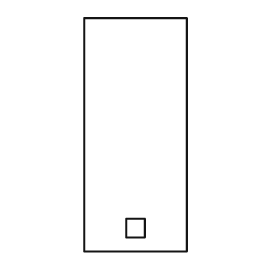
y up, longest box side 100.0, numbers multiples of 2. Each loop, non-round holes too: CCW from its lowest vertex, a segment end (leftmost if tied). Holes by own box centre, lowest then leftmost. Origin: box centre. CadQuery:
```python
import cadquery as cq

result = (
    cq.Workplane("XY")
    .moveTo(-22.0, -50.0)
    .lineTo(22.0, -50.0)
    .lineTo(22.0, 50.0)
    .lineTo(-22.0, 50.0)
    .close()
    .moveTo(-4.0, -44.0)
    .lineTo(4.0, -44.0)
    .lineTo(4.0, -36.0)
    .lineTo(-4.0, -36.0)
    .close()
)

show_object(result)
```